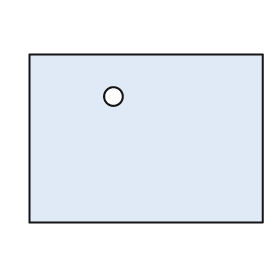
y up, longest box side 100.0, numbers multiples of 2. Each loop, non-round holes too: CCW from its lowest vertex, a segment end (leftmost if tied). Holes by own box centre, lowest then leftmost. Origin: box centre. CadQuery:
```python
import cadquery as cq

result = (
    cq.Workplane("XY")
    .moveTo(-50.0, -36.0)
    .lineTo(50.0, -36.0)
    .lineTo(50.0, 36.0)
    .lineTo(-50.0, 36.0)
    .close()
    .moveTo(-14.0, 18.0)
    .circle(4.0)
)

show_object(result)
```